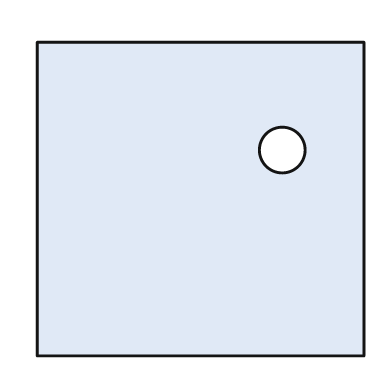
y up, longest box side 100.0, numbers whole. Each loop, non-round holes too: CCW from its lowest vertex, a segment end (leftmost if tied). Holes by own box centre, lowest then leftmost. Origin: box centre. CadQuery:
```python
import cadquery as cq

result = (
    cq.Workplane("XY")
    .moveTo(-50.0, -48.0)
    .lineTo(50.0, -48.0)
    .lineTo(50.0, 48.0)
    .lineTo(-50.0, 48.0)
    .close()
    .moveTo(25.0, 15.0)
    .circle(7.0)
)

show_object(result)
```